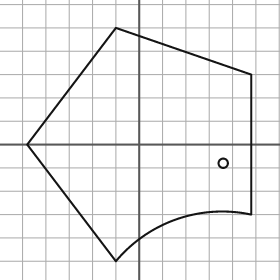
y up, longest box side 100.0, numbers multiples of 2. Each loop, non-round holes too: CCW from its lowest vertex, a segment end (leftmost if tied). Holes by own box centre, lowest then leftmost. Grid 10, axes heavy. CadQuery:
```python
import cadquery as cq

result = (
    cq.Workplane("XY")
    .moveTo(-10.0, -50.0)
    .threePointArc((16.0, -32.0), (48.0, -30.0))
    .lineTo(48.0, 30.0)
    .lineTo(-10.0, 50.0)
    .lineTo(-48.0, 0.0)
    .close()
    .moveTo(36.0, -8.0)
    .circle(2.0)
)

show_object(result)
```